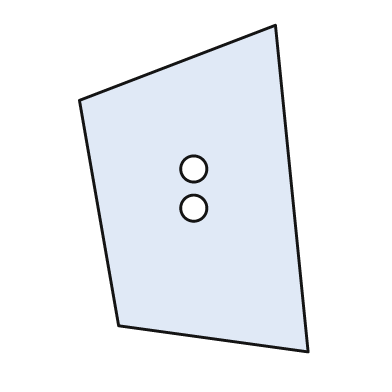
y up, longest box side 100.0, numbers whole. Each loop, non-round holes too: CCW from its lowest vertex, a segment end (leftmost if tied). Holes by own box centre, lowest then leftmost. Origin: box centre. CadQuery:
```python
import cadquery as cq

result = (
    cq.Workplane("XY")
    .moveTo(35.0, -50.0)
    .lineTo(25.0, 50.0)
    .lineTo(-35.0, 27.0)
    .lineTo(-23.0, -42.0)
    .close()
    .moveTo(0.0, -6.0)
    .circle(4.0)
    .moveTo(0.0, 6.0)
    .circle(4.0)
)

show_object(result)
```